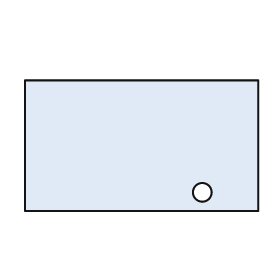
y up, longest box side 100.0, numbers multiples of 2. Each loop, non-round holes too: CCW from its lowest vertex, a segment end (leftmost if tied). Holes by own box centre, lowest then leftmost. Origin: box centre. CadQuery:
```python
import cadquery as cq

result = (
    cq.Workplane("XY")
    .moveTo(-50.0, -28.0)
    .lineTo(50.0, -28.0)
    .lineTo(50.0, 28.0)
    .lineTo(-50.0, 28.0)
    .close()
    .moveTo(26.0, -20.0)
    .circle(4.0)
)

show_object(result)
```